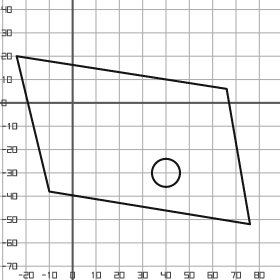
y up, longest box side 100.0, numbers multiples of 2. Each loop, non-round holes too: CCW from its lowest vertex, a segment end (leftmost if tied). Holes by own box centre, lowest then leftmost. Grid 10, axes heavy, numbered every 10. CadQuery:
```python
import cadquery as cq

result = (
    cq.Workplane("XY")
    .moveTo(76.0, -52.0)
    .lineTo(66.0, 6.0)
    .lineTo(-24.0, 20.0)
    .lineTo(-10.0, -38.0)
    .close()
    .moveTo(40.0, -30.0)
    .circle(6.0)
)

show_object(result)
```